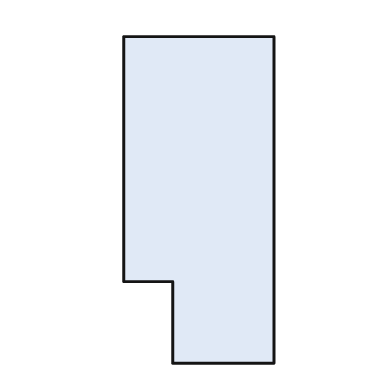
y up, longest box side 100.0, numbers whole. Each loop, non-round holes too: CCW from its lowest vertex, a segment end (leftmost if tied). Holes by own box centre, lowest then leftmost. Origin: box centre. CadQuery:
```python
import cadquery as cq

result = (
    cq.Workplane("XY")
    .moveTo(-8.0, -50.0)
    .lineTo(23.0, -50.0)
    .lineTo(23.0, 50.0)
    .lineTo(-23.0, 50.0)
    .lineTo(-23.0, -25.0)
    .lineTo(-8.0, -25.0)
    .close()
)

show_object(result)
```